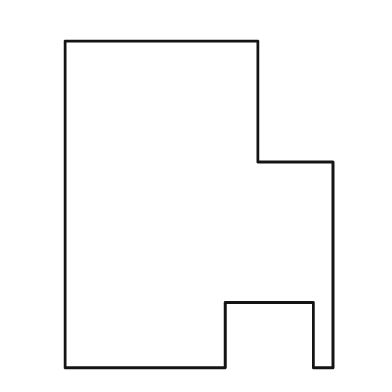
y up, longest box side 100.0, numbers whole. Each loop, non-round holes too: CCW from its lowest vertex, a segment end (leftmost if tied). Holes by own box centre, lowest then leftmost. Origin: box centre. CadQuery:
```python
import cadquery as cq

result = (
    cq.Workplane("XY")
    .moveTo(-41.0, -50.0)
    .lineTo(8.0, -50.0)
    .lineTo(8.0, -30.0)
    .lineTo(35.0, -30.0)
    .lineTo(35.0, -50.0)
    .lineTo(41.0, -50.0)
    .lineTo(41.0, 13.0)
    .lineTo(18.0, 13.0)
    .lineTo(18.0, 50.0)
    .lineTo(-41.0, 50.0)
    .close()
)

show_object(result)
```